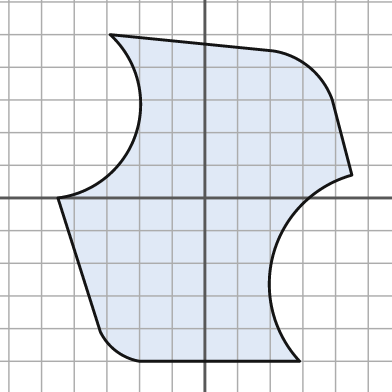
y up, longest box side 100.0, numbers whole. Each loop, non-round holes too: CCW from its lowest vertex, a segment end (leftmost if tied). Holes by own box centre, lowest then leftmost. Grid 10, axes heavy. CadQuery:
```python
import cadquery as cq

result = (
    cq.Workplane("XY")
    .moveTo(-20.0, -50.0)
    .lineTo(29.0, -50.0)
    .threePointArc((21.0, -17.0), (45.0, 7.0))
    .lineTo(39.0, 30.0)
    .threePointArc((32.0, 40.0), (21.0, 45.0))
    .lineTo(-29.0, 50.0)
    .threePointArc((-21.0, 20.0), (-45.0, 0.0))
    .lineTo(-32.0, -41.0)
    .threePointArc((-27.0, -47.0), (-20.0, -50.0))
    .close()
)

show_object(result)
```